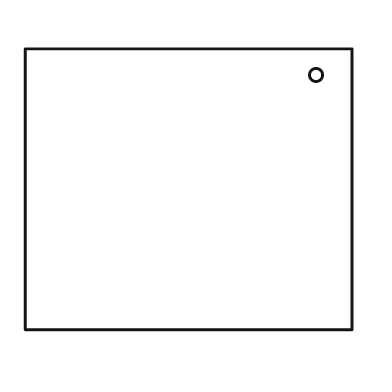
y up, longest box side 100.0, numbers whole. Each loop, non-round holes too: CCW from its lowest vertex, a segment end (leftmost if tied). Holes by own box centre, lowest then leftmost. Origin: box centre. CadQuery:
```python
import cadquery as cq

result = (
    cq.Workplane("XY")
    .moveTo(-50.0, -43.0)
    .lineTo(50.0, -43.0)
    .lineTo(50.0, 43.0)
    .lineTo(-50.0, 43.0)
    .close()
    .moveTo(39.0, 35.0)
    .circle(2.0)
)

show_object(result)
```